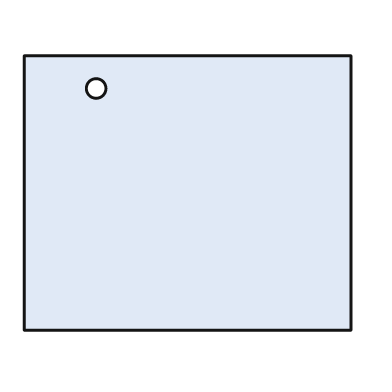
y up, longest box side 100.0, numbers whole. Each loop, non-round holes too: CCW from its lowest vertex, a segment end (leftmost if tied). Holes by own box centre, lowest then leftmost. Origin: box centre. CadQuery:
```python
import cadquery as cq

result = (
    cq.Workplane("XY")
    .moveTo(-50.0, -42.0)
    .lineTo(50.0, -42.0)
    .lineTo(50.0, 42.0)
    .lineTo(-50.0, 42.0)
    .close()
    .moveTo(-28.0, 32.0)
    .circle(3.0)
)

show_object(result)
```